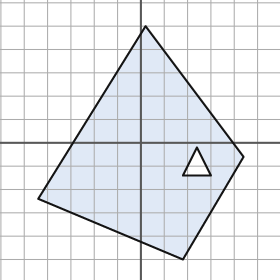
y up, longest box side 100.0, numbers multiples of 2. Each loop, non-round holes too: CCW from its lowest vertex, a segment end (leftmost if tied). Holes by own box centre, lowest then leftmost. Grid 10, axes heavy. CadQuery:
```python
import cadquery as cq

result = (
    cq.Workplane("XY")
    .moveTo(18.0, -50.0)
    .lineTo(44.0, -6.0)
    .lineTo(2.0, 50.0)
    .lineTo(-44.0, -24.0)
    .close()
    .moveTo(18.0, -14.0)
    .lineTo(30.0, -14.0)
    .lineTo(24.0, -2.0)
    .close()
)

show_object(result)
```